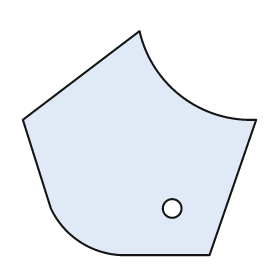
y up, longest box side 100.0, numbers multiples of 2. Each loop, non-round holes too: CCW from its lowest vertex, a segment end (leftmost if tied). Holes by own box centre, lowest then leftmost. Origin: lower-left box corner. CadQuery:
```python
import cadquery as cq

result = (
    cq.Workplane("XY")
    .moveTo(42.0, 0.0)
    .lineTo(80.0, 0.0)
    .lineTo(100.0, 58.0)
    .threePointArc((68.0, 68.0), (50.0, 96.0))
    .lineTo(0.0, 58.0)
    .lineTo(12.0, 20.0)
    .threePointArc((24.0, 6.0), (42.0, 0.0))
    .close()
    .moveTo(64.0, 20.0)
    .circle(4.0)
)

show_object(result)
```